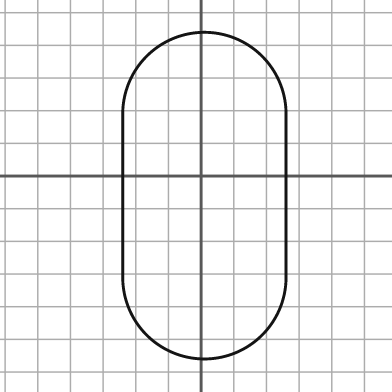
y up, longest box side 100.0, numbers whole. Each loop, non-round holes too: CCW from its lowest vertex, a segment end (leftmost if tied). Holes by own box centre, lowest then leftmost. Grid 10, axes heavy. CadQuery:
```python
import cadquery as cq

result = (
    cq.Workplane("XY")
    .moveTo(-24.0, -31.0)
    .threePointArc((1.0, -56.0), (26.0, -31.0))
    .lineTo(26.0, 19.0)
    .threePointArc((1.0, 44.0), (-24.0, 19.0))
    .close()
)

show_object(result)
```